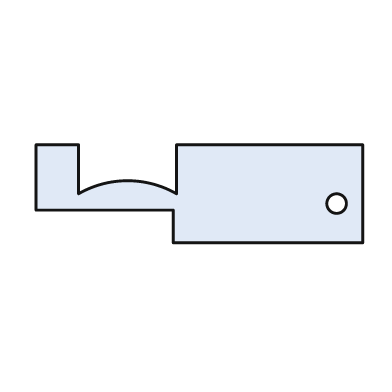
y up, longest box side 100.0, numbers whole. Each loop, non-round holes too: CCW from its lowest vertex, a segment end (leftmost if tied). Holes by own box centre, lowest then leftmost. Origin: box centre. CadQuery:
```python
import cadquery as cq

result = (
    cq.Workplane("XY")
    .moveTo(-8.0, -15.0)
    .lineTo(50.0, -15.0)
    .lineTo(50.0, 15.0)
    .lineTo(-7.0, 15.0)
    .lineTo(-7.0, 0.0)
    .threePointArc((-22.0, 4.0), (-37.0, 0.0))
    .lineTo(-37.0, 15.0)
    .lineTo(-50.0, 15.0)
    .lineTo(-50.0, -5.0)
    .lineTo(-8.0, -5.0)
    .close()
    .moveTo(42.0, -3.0)
    .circle(3.0)
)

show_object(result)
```